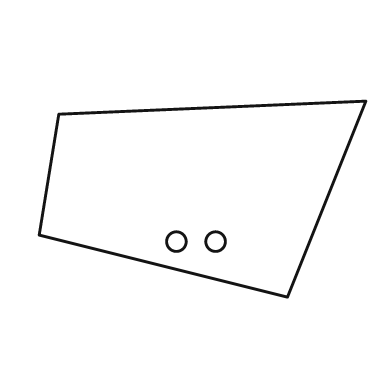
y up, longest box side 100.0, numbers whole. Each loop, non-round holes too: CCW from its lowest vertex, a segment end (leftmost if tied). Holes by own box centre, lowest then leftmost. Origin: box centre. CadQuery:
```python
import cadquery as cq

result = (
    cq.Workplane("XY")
    .moveTo(26.0, -30.0)
    .lineTo(50.0, 30.0)
    .lineTo(-44.0, 26.0)
    .lineTo(-50.0, -11.0)
    .close()
    .moveTo(-8.0, -13.0)
    .circle(3.0)
    .moveTo(4.0, -13.0)
    .circle(3.0)
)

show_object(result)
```